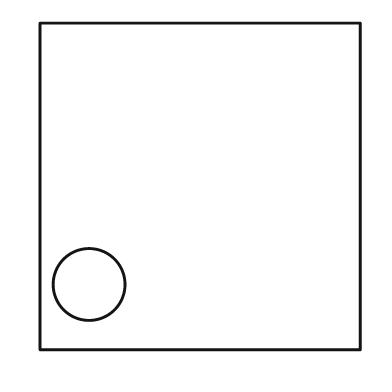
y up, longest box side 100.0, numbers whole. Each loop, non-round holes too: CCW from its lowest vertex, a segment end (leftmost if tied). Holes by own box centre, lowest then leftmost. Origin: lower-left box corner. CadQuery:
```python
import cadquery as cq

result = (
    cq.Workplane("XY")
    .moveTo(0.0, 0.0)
    .lineTo(98.0, 0.0)
    .lineTo(98.0, 100.0)
    .lineTo(0.0, 100.0)
    .close()
    .moveTo(15.0, 20.0)
    .circle(11.0)
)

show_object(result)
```